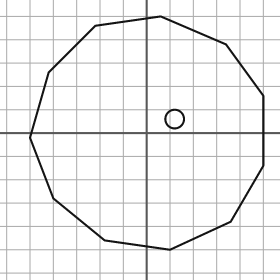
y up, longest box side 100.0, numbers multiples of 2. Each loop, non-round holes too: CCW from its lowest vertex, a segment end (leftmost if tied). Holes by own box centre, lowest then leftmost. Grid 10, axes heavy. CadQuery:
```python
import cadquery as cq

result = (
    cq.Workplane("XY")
    .moveTo(10.0, -50.0)
    .lineTo(36.0, -38.0)
    .lineTo(50.0, -14.0)
    .lineTo(50.0, 16.0)
    .lineTo(34.0, 38.0)
    .lineTo(6.0, 50.0)
    .lineTo(-22.0, 46.0)
    .lineTo(-42.0, 26.0)
    .lineTo(-50.0, -2.0)
    .lineTo(-40.0, -28.0)
    .lineTo(-18.0, -46.0)
    .close()
    .moveTo(12.0, 6.0)
    .circle(4.0)
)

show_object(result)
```